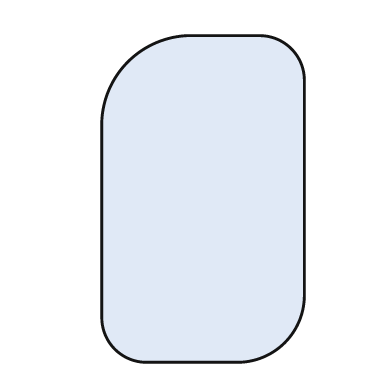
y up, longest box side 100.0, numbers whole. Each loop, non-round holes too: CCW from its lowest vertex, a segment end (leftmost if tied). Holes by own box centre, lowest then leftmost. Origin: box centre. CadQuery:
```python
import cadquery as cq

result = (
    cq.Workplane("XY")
    .moveTo(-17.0, -50.0)
    .lineTo(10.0, -50.0)
    .threePointArc((25.0, -44.0), (31.0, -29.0))
    .lineTo(31.0, 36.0)
    .threePointArc((27.0, 46.0), (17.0, 50.0))
    .lineTo(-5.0, 50.0)
    .threePointArc((-23.0, 42.0), (-31.0, 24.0))
    .lineTo(-31.0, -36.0)
    .threePointArc((-27.0, -46.0), (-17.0, -50.0))
    .close()
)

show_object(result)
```